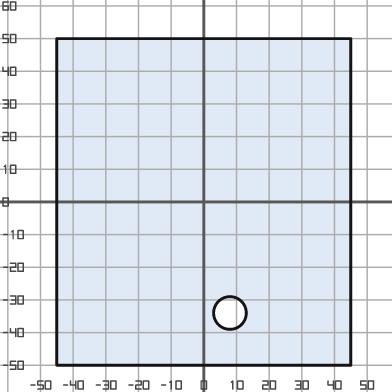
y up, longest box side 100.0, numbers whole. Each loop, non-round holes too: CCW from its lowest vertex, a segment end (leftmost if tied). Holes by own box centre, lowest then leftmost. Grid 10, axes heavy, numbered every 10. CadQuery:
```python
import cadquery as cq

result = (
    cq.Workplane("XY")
    .moveTo(-45.0, -50.0)
    .lineTo(45.0, -50.0)
    .lineTo(45.0, 50.0)
    .lineTo(-45.0, 50.0)
    .close()
    .moveTo(8.0, -34.0)
    .circle(5.0)
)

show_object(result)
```